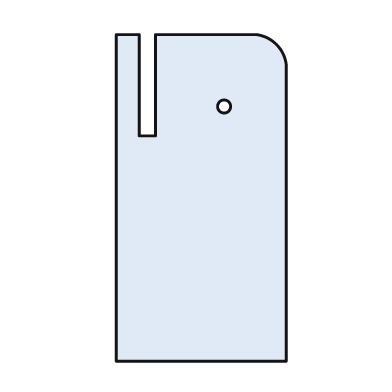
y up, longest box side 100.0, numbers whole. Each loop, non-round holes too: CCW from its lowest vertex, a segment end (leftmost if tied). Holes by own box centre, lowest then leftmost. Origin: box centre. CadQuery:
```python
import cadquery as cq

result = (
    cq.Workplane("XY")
    .moveTo(-26.0, -50.0)
    .lineTo(26.0, -50.0)
    .lineTo(26.0, 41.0)
    .threePointArc((23.0, 47.0), (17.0, 50.0))
    .lineTo(-14.0, 50.0)
    .lineTo(-14.0, 19.0)
    .lineTo(-19.0, 19.0)
    .lineTo(-19.0, 50.0)
    .lineTo(-26.0, 50.0)
    .close()
    .moveTo(7.0, 28.0)
    .circle(2.0)
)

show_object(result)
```